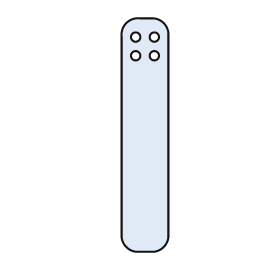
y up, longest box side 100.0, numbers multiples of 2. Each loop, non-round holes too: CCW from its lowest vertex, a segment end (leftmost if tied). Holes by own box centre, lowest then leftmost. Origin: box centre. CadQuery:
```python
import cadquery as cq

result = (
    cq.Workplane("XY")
    .moveTo(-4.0, -50.0)
    .lineTo(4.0, -50.0)
    .threePointArc((8.0, -48.0), (10.0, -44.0))
    .lineTo(10.0, 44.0)
    .threePointArc((8.0, 48.0), (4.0, 50.0))
    .lineTo(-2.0, 50.0)
    .threePointArc((-8.0, 48.0), (-10.0, 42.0))
    .lineTo(-10.0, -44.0)
    .threePointArc((-8.0, -48.0), (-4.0, -50.0))
    .close()
    .moveTo(-4.0, 34.0)
    .circle(2.0)
    .moveTo(4.0, 34.0)
    .circle(2.0)
    .moveTo(-4.0, 42.0)
    .circle(2.0)
    .moveTo(4.0, 42.0)
    .circle(2.0)
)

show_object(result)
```